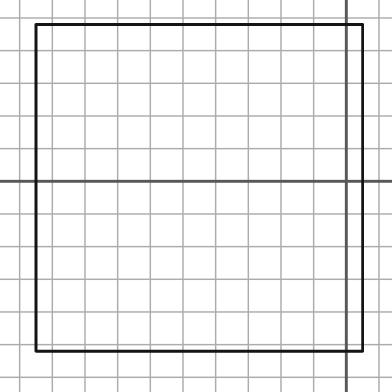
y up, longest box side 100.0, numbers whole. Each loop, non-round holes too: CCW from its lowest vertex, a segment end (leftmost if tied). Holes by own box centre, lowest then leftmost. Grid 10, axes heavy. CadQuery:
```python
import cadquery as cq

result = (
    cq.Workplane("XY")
    .moveTo(-95.0, -52.0)
    .lineTo(5.0, -52.0)
    .lineTo(5.0, 48.0)
    .lineTo(-95.0, 48.0)
    .close()
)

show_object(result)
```